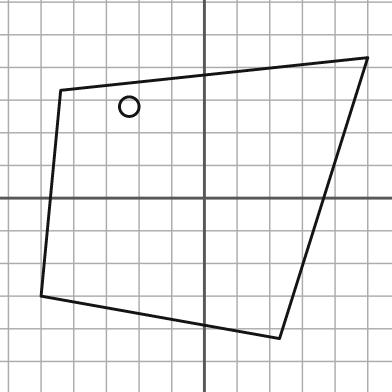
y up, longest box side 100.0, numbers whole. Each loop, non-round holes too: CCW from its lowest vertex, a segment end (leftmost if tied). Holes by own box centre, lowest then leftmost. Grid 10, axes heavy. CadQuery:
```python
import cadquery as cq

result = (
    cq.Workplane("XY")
    .moveTo(23.0, -43.0)
    .lineTo(50.0, 43.0)
    .lineTo(-44.0, 33.0)
    .lineTo(-50.0, -30.0)
    .close()
    .moveTo(-23.0, 28.0)
    .circle(3.0)
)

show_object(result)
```